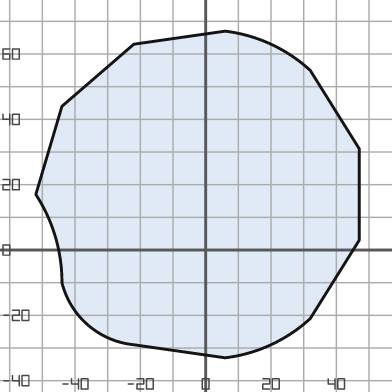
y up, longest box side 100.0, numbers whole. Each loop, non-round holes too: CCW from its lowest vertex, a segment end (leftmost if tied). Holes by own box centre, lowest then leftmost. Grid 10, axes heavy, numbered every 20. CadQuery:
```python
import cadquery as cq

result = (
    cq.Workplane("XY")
    .moveTo(6.0, -33.0)
    .threePointArc((20.0, -29.0), (32.0, -21.0))
    .lineTo(47.0, 3.0)
    .lineTo(47.0, 31.0)
    .lineTo(32.0, 55.0)
    .threePointArc((20.0, 63.0), (6.0, 67.0))
    .lineTo(-22.0, 63.0)
    .lineTo(-44.0, 44.0)
    .lineTo(-52.0, 17.0)
    .threePointArc((-46.0, 4.0), (-44.0, -10.0))
    .threePointArc((-36.0, -23.0), (-22.0, -29.0))
    .close()
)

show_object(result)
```